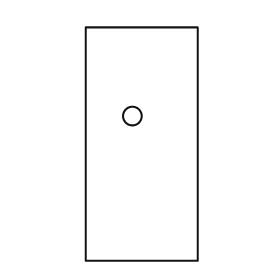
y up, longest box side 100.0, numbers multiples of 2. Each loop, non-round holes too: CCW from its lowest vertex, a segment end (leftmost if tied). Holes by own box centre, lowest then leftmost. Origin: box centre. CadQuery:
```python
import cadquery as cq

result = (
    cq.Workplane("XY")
    .moveTo(-24.0, -50.0)
    .lineTo(24.0, -50.0)
    .lineTo(24.0, 50.0)
    .lineTo(-24.0, 50.0)
    .close()
    .moveTo(-4.0, 12.0)
    .circle(4.0)
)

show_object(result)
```